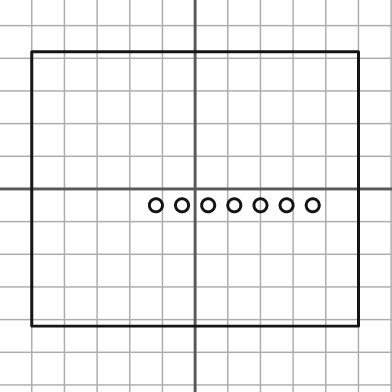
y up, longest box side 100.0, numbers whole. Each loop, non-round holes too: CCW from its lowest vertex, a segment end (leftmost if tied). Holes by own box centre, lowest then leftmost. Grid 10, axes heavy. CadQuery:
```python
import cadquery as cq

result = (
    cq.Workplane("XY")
    .moveTo(-50.0, -42.0)
    .lineTo(50.0, -42.0)
    .lineTo(50.0, 42.0)
    .lineTo(-50.0, 42.0)
    .close()
    .moveTo(-12.0, -5.0)
    .circle(2.0)
    .moveTo(-4.0, -5.0)
    .circle(2.0)
    .moveTo(4.0, -5.0)
    .circle(2.0)
    .moveTo(12.0, -5.0)
    .circle(2.0)
    .moveTo(20.0, -5.0)
    .circle(2.0)
    .moveTo(28.0, -5.0)
    .circle(2.0)
    .moveTo(36.0, -5.0)
    .circle(2.0)
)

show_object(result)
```